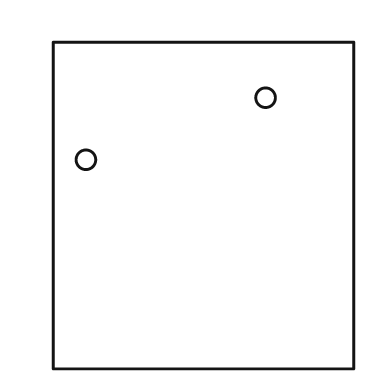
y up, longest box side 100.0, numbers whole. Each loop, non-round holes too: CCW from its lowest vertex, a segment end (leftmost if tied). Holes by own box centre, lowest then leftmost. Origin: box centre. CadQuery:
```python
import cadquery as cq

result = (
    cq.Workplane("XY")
    .moveTo(-46.0, -50.0)
    .lineTo(46.0, -50.0)
    .lineTo(46.0, 50.0)
    .lineTo(-46.0, 50.0)
    .close()
    .moveTo(-36.0, 14.0)
    .circle(3.0)
    .moveTo(19.0, 33.0)
    .circle(3.0)
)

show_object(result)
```